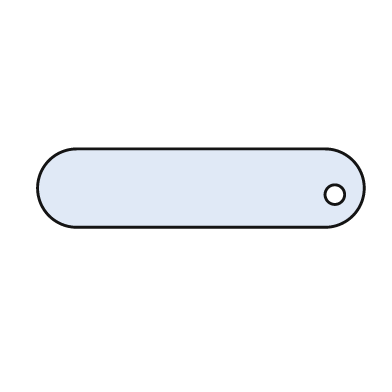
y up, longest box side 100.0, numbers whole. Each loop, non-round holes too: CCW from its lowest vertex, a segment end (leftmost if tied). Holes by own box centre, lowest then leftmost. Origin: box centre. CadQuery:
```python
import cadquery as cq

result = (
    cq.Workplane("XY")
    .moveTo(-38.0, -12.0)
    .lineTo(38.0, -12.0)
    .threePointArc((50.0, 0.0), (38.0, 12.0))
    .lineTo(-38.0, 12.0)
    .threePointArc((-50.0, 0.0), (-38.0, -12.0))
    .close()
    .moveTo(41.0, -2.0)
    .circle(3.0)
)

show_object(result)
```